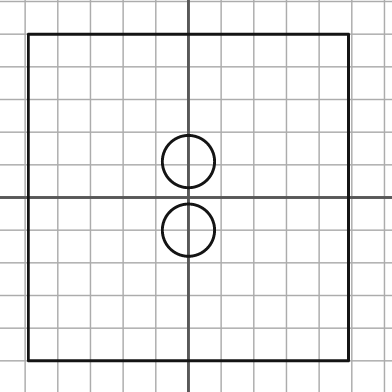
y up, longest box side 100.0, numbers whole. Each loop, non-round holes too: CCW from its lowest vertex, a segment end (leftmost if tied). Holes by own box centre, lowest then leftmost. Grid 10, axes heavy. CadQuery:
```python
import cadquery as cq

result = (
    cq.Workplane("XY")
    .moveTo(-49.0, -50.0)
    .lineTo(49.0, -50.0)
    .lineTo(49.0, 50.0)
    .lineTo(-49.0, 50.0)
    .close()
    .moveTo(0.0, -10.0)
    .circle(8.0)
    .moveTo(0.0, 11.0)
    .circle(8.0)
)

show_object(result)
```